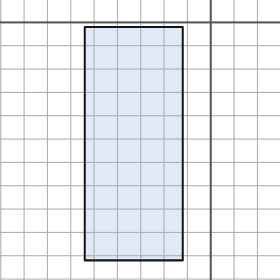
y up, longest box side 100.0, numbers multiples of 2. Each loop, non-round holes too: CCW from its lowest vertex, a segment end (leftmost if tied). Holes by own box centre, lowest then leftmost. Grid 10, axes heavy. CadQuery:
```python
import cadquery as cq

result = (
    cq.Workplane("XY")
    .moveTo(-54.0, -102.0)
    .lineTo(-12.0, -102.0)
    .lineTo(-12.0, -2.0)
    .lineTo(-54.0, -2.0)
    .close()
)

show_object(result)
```